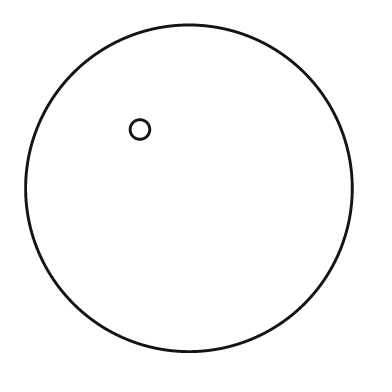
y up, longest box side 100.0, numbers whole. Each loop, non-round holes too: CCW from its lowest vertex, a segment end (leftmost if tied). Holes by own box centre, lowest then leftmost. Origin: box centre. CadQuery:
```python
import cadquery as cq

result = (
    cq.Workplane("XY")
    .moveTo(0.0, 0.0)
    .circle(50.0)
    .moveTo(-15.0, 18.0)
    .circle(3.0)
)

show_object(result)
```